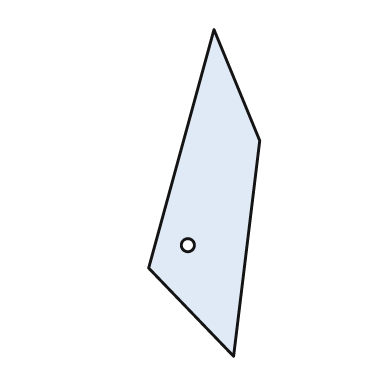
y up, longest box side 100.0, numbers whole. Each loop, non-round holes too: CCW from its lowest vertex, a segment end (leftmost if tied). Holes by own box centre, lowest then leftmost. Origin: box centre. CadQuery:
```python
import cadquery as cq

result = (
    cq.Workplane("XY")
    .moveTo(9.0, -50.0)
    .lineTo(17.0, 16.0)
    .lineTo(3.0, 50.0)
    .lineTo(-17.0, -23.0)
    .close()
    .moveTo(-5.0, -16.0)
    .circle(2.0)
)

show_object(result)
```